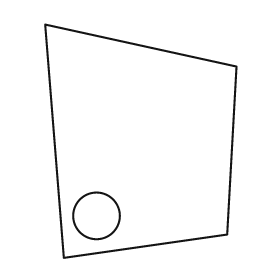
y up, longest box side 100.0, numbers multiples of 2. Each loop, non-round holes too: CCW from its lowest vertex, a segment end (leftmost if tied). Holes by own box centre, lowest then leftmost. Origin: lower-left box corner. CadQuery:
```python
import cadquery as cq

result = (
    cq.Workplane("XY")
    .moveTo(8.0, 0.0)
    .lineTo(78.0, 10.0)
    .lineTo(82.0, 82.0)
    .lineTo(0.0, 100.0)
    .close()
    .moveTo(22.0, 18.0)
    .circle(10.0)
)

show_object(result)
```